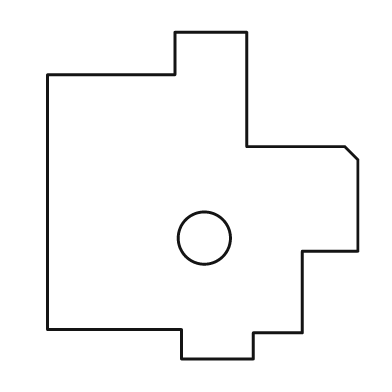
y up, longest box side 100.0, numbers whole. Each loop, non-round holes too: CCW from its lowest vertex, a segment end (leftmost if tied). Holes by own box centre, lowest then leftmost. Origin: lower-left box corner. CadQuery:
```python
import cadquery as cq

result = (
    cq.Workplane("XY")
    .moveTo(41.0, 0.0)
    .lineTo(63.0, 0.0)
    .lineTo(63.0, 8.0)
    .lineTo(78.0, 8.0)
    .lineTo(78.0, 33.0)
    .lineTo(95.0, 33.0)
    .lineTo(95.0, 61.0)
    .lineTo(91.0, 65.0)
    .lineTo(61.0, 65.0)
    .lineTo(61.0, 100.0)
    .lineTo(39.0, 100.0)
    .lineTo(39.0, 87.0)
    .lineTo(0.0, 87.0)
    .lineTo(0.0, 9.0)
    .lineTo(41.0, 9.0)
    .close()
    .moveTo(48.0, 37.0)
    .circle(8.0)
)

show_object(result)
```